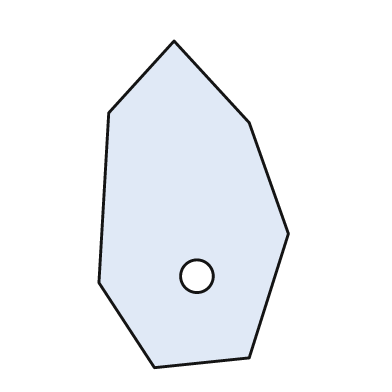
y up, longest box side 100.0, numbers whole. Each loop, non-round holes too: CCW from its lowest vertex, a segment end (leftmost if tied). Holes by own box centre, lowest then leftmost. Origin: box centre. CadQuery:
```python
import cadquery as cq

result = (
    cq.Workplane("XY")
    .moveTo(-12.0, -50.0)
    .lineTo(17.0, -47.0)
    .lineTo(29.0, -9.0)
    .lineTo(17.0, 25.0)
    .lineTo(-6.0, 50.0)
    .lineTo(-26.0, 28.0)
    .lineTo(-29.0, -24.0)
    .close()
    .moveTo(1.0, -22.0)
    .circle(5.0)
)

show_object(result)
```